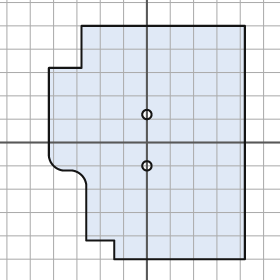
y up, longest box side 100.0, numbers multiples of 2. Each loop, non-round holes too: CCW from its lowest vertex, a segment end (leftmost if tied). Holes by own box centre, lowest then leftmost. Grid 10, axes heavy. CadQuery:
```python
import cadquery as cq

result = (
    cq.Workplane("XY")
    .moveTo(-14.0, -50.0)
    .lineTo(42.0, -50.0)
    .lineTo(42.0, 50.0)
    .lineTo(-28.0, 50.0)
    .lineTo(-28.0, 32.0)
    .lineTo(-42.0, 32.0)
    .lineTo(-42.0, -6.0)
    .threePointArc((-40.0, -10.0), (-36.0, -12.0))
    .lineTo(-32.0, -12.0)
    .threePointArc((-28.0, -14.0), (-26.0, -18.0))
    .lineTo(-26.0, -42.0)
    .lineTo(-14.0, -42.0)
    .close()
    .moveTo(0.0, -10.0)
    .circle(2.0)
    .moveTo(0.0, 12.0)
    .circle(2.0)
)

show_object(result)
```